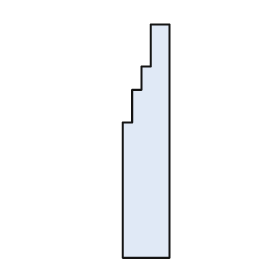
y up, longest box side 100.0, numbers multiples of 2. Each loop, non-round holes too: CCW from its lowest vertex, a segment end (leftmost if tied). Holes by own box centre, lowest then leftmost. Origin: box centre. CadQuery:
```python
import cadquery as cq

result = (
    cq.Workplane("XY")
    .moveTo(-10.0, -50.0)
    .lineTo(10.0, -50.0)
    .lineTo(10.0, 50.0)
    .lineTo(2.0, 50.0)
    .lineTo(2.0, 32.0)
    .lineTo(-2.0, 32.0)
    .lineTo(-2.0, 22.0)
    .lineTo(-6.0, 22.0)
    .lineTo(-6.0, 8.0)
    .lineTo(-10.0, 8.0)
    .close()
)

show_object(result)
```